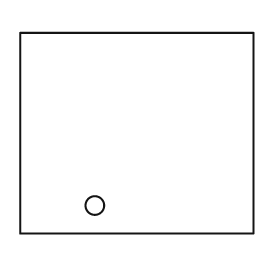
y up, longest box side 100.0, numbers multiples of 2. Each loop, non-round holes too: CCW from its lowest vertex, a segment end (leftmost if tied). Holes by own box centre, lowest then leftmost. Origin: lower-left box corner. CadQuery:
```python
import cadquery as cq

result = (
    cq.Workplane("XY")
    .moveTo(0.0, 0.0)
    .lineTo(100.0, 0.0)
    .lineTo(100.0, 86.0)
    .lineTo(0.0, 86.0)
    .close()
    .moveTo(32.0, 12.0)
    .circle(4.0)
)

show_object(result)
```